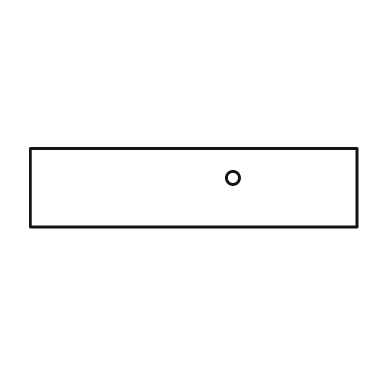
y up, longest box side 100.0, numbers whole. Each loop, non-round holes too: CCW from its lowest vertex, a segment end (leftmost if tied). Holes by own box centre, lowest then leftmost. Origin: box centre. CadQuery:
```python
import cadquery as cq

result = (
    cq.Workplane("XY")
    .moveTo(-50.0, -12.0)
    .lineTo(50.0, -12.0)
    .lineTo(50.0, 12.0)
    .lineTo(-50.0, 12.0)
    .close()
    .moveTo(12.0, 3.0)
    .circle(2.0)
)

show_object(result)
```